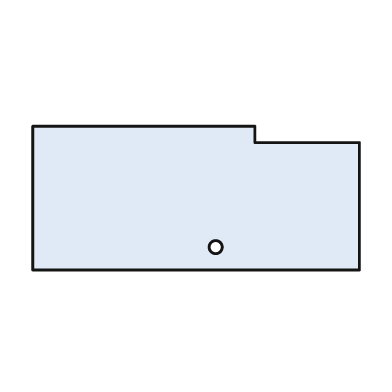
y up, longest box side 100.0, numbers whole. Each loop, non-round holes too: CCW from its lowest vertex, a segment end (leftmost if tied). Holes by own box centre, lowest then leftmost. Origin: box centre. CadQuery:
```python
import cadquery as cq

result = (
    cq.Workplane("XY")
    .moveTo(-50.0, -22.0)
    .lineTo(50.0, -22.0)
    .lineTo(50.0, 17.0)
    .lineTo(18.0, 17.0)
    .lineTo(18.0, 22.0)
    .lineTo(-50.0, 22.0)
    .close()
    .moveTo(6.0, -15.0)
    .circle(2.0)
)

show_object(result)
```